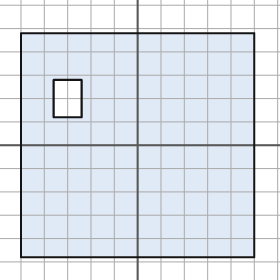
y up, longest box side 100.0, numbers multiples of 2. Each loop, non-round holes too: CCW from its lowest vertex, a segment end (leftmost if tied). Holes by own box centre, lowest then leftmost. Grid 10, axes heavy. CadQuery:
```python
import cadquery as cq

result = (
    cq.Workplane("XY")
    .moveTo(-50.0, -48.0)
    .lineTo(50.0, -48.0)
    .lineTo(50.0, 48.0)
    .lineTo(-50.0, 48.0)
    .close()
    .moveTo(-36.0, 12.0)
    .lineTo(-24.0, 12.0)
    .lineTo(-24.0, 28.0)
    .lineTo(-36.0, 28.0)
    .close()
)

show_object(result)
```